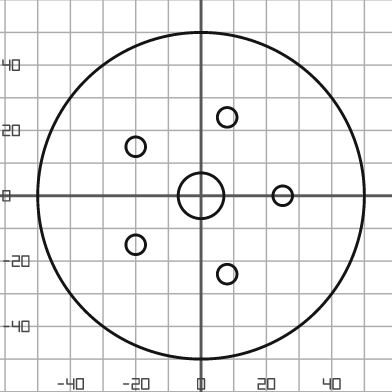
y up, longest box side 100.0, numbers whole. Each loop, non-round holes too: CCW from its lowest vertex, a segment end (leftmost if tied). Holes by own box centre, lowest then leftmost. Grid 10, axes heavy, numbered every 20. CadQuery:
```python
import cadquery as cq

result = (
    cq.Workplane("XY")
    .moveTo(0.0, 0.0)
    .circle(50.0)
    .moveTo(8.0, -24.0)
    .circle(3.0)
    .moveTo(-20.0, -15.0)
    .circle(3.0)
    .moveTo(0.0, 0.0)
    .circle(7.0)
    .moveTo(25.0, 0.0)
    .circle(3.0)
    .moveTo(-20.0, 15.0)
    .circle(3.0)
    .moveTo(8.0, 24.0)
    .circle(3.0)
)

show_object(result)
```